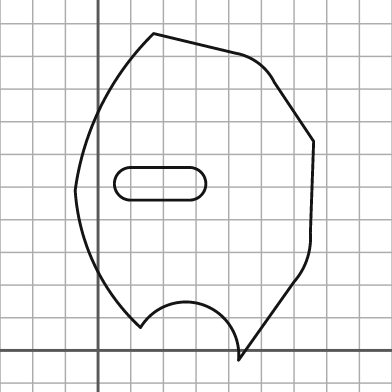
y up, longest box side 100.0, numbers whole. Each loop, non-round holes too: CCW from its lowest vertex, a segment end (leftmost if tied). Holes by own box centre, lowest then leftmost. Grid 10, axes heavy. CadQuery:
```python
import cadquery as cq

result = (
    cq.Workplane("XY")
    .moveTo(43.0, -3.0)
    .lineTo(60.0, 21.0)
    .threePointArc((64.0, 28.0), (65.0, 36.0))
    .lineTo(66.0, 64.0)
    .lineTo(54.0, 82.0)
    .threePointArc((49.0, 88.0), (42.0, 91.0))
    .lineTo(17.0, 97.0)
    .threePointArc((1.0, 75.0), (-7.0, 49.0))
    .threePointArc((-1.0, 26.0), (13.0, 7.0))
    .threePointArc((32.0, 14.0), (43.0, -3.0))
    .close()
    .moveTo(10.0, 46.0)
    .lineTo(28.0, 46.0)
    .threePointArc((33.0, 51.0), (28.0, 56.0))
    .lineTo(10.0, 56.0)
    .threePointArc((5.0, 51.0), (10.0, 46.0))
    .close()
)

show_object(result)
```